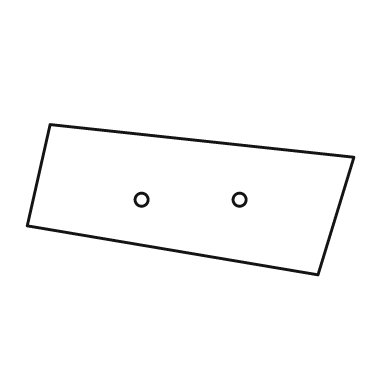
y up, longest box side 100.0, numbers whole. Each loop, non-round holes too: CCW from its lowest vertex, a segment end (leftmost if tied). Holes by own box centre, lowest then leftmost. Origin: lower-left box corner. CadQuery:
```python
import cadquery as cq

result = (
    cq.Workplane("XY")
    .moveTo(89.0, 0.0)
    .lineTo(100.0, 36.0)
    .lineTo(7.0, 46.0)
    .lineTo(0.0, 15.0)
    .close()
    .moveTo(35.0, 23.0)
    .circle(2.0)
    .moveTo(65.0, 23.0)
    .circle(2.0)
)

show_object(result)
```